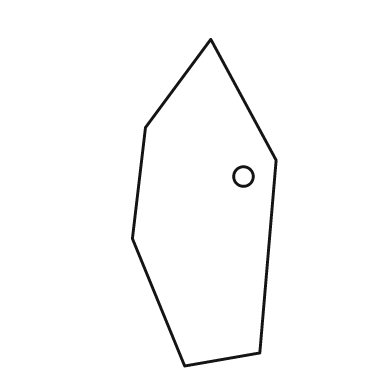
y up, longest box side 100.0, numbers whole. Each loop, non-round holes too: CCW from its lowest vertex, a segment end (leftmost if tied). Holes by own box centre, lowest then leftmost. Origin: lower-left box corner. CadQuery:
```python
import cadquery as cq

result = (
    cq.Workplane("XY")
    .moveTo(16.0, 0.0)
    .lineTo(39.0, 4.0)
    .lineTo(44.0, 63.0)
    .lineTo(24.0, 100.0)
    .lineTo(4.0, 73.0)
    .lineTo(0.0, 39.0)
    .close()
    .moveTo(34.0, 58.0)
    .circle(3.0)
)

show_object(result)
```